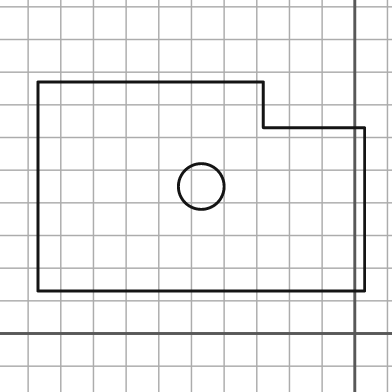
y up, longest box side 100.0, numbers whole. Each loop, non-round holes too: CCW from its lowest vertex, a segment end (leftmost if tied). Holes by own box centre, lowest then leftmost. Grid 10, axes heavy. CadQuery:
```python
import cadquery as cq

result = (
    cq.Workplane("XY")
    .moveTo(-97.0, 13.0)
    .lineTo(3.0, 13.0)
    .lineTo(3.0, 63.0)
    .lineTo(-28.0, 63.0)
    .lineTo(-28.0, 77.0)
    .lineTo(-97.0, 77.0)
    .close()
    .moveTo(-47.0, 45.0)
    .circle(7.0)
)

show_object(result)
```